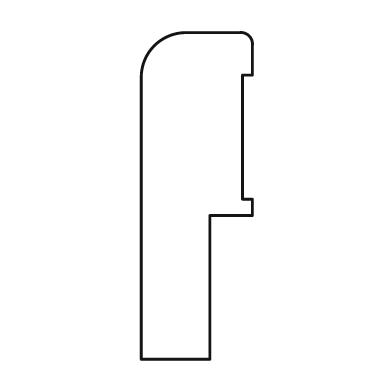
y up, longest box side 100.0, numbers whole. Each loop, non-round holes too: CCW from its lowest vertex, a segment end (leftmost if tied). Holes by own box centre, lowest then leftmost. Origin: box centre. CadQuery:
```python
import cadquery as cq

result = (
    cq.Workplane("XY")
    .moveTo(-17.0, -50.0)
    .lineTo(4.0, -50.0)
    .lineTo(4.0, -6.0)
    .lineTo(17.0, -6.0)
    .lineTo(17.0, -1.0)
    .lineTo(14.0, -1.0)
    .lineTo(14.0, 37.0)
    .lineTo(17.0, 37.0)
    .lineTo(17.0, 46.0)
    .threePointArc((16.0, 49.0), (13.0, 50.0))
    .lineTo(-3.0, 50.0)
    .threePointArc((-13.0, 46.0), (-17.0, 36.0))
    .close()
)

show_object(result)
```